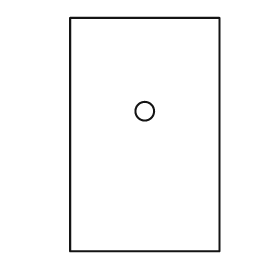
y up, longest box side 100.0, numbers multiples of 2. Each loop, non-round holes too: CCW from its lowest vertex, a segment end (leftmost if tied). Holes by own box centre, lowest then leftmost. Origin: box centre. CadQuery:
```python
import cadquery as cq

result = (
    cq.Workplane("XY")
    .moveTo(-32.0, -50.0)
    .lineTo(32.0, -50.0)
    .lineTo(32.0, 50.0)
    .lineTo(-32.0, 50.0)
    .close()
    .moveTo(0.0, 10.0)
    .circle(4.0)
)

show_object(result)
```